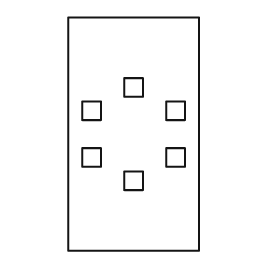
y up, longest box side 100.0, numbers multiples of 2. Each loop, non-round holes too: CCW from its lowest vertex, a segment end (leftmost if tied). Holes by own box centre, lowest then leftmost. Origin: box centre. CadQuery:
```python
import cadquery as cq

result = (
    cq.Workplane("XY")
    .moveTo(-28.0, -50.0)
    .lineTo(28.0, -50.0)
    .lineTo(28.0, 50.0)
    .lineTo(-28.0, 50.0)
    .close()
    .moveTo(-4.0, -24.0)
    .lineTo(4.0, -24.0)
    .lineTo(4.0, -16.0)
    .lineTo(-4.0, -16.0)
    .close()
    .moveTo(-22.0, -14.0)
    .lineTo(-14.0, -14.0)
    .lineTo(-14.0, -6.0)
    .lineTo(-22.0, -6.0)
    .close()
    .moveTo(14.0, -14.0)
    .lineTo(22.0, -14.0)
    .lineTo(22.0, -6.0)
    .lineTo(14.0, -6.0)
    .close()
    .moveTo(-22.0, 6.0)
    .lineTo(-14.0, 6.0)
    .lineTo(-14.0, 14.0)
    .lineTo(-22.0, 14.0)
    .close()
    .moveTo(14.0, 6.0)
    .lineTo(22.0, 6.0)
    .lineTo(22.0, 14.0)
    .lineTo(14.0, 14.0)
    .close()
    .moveTo(-4.0, 16.0)
    .lineTo(4.0, 16.0)
    .lineTo(4.0, 24.0)
    .lineTo(-4.0, 24.0)
    .close()
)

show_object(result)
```